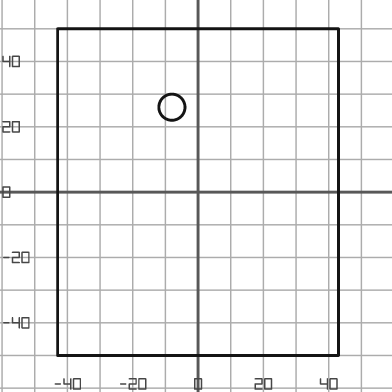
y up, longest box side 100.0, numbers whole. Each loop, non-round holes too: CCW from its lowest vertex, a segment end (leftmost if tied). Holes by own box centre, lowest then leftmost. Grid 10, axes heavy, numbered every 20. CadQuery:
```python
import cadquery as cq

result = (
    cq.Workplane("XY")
    .moveTo(-43.0, -50.0)
    .lineTo(43.0, -50.0)
    .lineTo(43.0, 50.0)
    .lineTo(-43.0, 50.0)
    .close()
    .moveTo(-8.0, 26.0)
    .circle(4.0)
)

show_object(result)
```